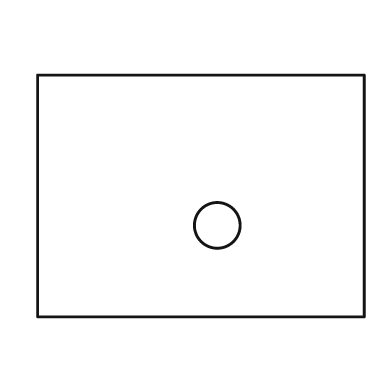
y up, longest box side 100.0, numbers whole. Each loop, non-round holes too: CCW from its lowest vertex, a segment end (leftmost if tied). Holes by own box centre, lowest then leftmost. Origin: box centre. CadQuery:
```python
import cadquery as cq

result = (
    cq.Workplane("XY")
    .moveTo(-50.0, -37.0)
    .lineTo(50.0, -37.0)
    .lineTo(50.0, 37.0)
    .lineTo(-50.0, 37.0)
    .close()
    .moveTo(5.0, -9.0)
    .circle(7.0)
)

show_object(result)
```